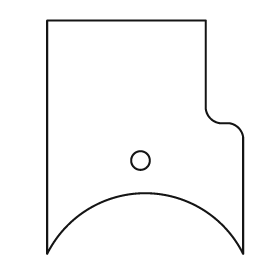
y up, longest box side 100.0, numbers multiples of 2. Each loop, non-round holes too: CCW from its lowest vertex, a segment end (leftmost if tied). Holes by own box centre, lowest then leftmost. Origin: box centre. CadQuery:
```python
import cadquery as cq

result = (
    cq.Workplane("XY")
    .moveTo(-42.0, -50.0)
    .threePointArc((0.0, -24.0), (42.0, -50.0))
    .lineTo(42.0, 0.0)
    .threePointArc((40.0, 4.0), (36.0, 6.0))
    .lineTo(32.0, 6.0)
    .threePointArc((28.0, 8.0), (26.0, 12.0))
    .lineTo(26.0, 50.0)
    .lineTo(-42.0, 50.0)
    .close()
    .moveTo(-2.0, -10.0)
    .circle(4.0)
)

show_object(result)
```